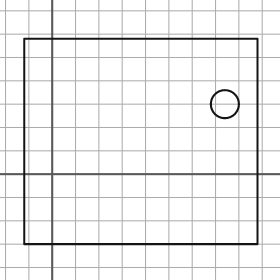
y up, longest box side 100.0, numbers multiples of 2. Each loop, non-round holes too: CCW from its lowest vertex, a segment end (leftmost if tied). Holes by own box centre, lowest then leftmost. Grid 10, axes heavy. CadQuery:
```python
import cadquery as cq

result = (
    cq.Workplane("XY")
    .moveTo(-12.0, -30.0)
    .lineTo(88.0, -30.0)
    .lineTo(88.0, 58.0)
    .lineTo(-12.0, 58.0)
    .close()
    .moveTo(74.0, 30.0)
    .circle(6.0)
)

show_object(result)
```